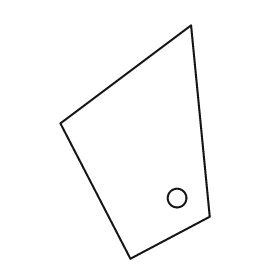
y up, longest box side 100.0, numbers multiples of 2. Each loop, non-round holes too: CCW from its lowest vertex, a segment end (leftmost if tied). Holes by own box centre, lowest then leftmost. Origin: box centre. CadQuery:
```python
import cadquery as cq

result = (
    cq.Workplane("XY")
    .moveTo(-2.0, -50.0)
    .lineTo(32.0, -32.0)
    .lineTo(24.0, 50.0)
    .lineTo(-32.0, 8.0)
    .close()
    .moveTo(18.0, -24.0)
    .circle(4.0)
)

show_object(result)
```